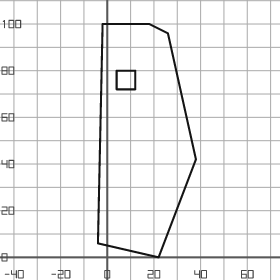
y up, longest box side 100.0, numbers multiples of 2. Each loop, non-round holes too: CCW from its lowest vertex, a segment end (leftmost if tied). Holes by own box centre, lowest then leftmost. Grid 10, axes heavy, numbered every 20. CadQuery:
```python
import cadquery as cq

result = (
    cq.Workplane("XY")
    .moveTo(22.0, 0.0)
    .lineTo(38.0, 42.0)
    .lineTo(26.0, 96.0)
    .lineTo(18.0, 100.0)
    .lineTo(-2.0, 100.0)
    .lineTo(-4.0, 6.0)
    .close()
    .moveTo(4.0, 72.0)
    .lineTo(12.0, 72.0)
    .lineTo(12.0, 80.0)
    .lineTo(4.0, 80.0)
    .close()
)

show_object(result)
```